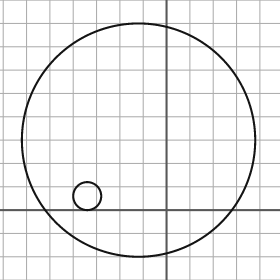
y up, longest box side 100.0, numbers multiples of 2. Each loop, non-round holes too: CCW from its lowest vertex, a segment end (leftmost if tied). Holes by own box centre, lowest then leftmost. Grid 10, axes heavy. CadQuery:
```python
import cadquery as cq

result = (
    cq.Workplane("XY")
    .moveTo(-12.0, 30.0)
    .circle(50.0)
    .moveTo(-34.0, 6.0)
    .circle(6.0)
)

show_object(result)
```